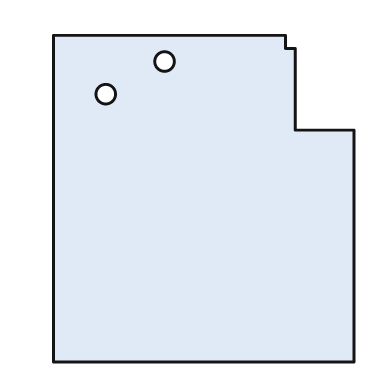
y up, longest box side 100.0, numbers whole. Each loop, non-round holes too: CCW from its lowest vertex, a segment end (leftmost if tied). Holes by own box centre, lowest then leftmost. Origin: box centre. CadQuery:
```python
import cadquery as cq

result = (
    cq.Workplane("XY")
    .moveTo(-46.0, -50.0)
    .lineTo(46.0, -50.0)
    .lineTo(46.0, 21.0)
    .lineTo(28.0, 21.0)
    .lineTo(28.0, 46.0)
    .lineTo(25.0, 46.0)
    .lineTo(25.0, 50.0)
    .lineTo(-46.0, 50.0)
    .close()
    .moveTo(-30.0, 32.0)
    .circle(3.0)
    .moveTo(-12.0, 42.0)
    .circle(3.0)
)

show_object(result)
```